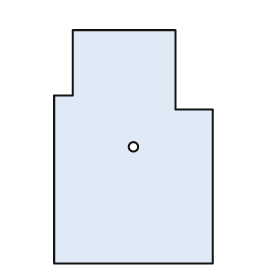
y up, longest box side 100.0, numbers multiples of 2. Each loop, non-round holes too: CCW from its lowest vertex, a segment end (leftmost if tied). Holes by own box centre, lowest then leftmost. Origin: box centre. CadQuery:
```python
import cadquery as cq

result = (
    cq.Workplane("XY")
    .moveTo(-34.0, -50.0)
    .lineTo(34.0, -50.0)
    .lineTo(34.0, 16.0)
    .lineTo(18.0, 16.0)
    .lineTo(18.0, 50.0)
    .lineTo(-26.0, 50.0)
    .lineTo(-26.0, 22.0)
    .lineTo(-34.0, 22.0)
    .close()
    .moveTo(0.0, 0.0)
    .circle(2.0)
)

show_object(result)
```